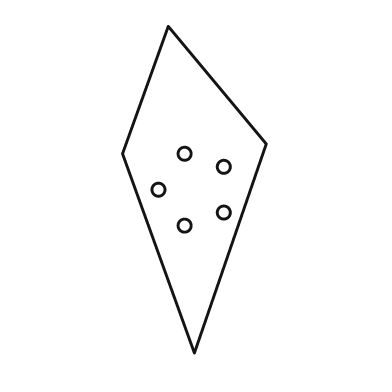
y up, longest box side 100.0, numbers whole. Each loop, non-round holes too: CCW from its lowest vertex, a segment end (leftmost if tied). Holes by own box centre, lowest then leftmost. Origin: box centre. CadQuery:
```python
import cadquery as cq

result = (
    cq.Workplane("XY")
    .moveTo(0.0, -50.0)
    .lineTo(22.0, 14.0)
    .lineTo(-8.0, 50.0)
    .lineTo(-22.0, 11.0)
    .close()
    .moveTo(-3.0, -11.0)
    .circle(2.0)
    .moveTo(9.0, -7.0)
    .circle(2.0)
    .moveTo(-11.0, 0.0)
    .circle(2.0)
    .moveTo(9.0, 7.0)
    .circle(2.0)
    .moveTo(-3.0, 11.0)
    .circle(2.0)
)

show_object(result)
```